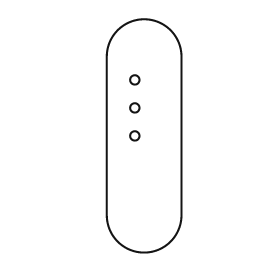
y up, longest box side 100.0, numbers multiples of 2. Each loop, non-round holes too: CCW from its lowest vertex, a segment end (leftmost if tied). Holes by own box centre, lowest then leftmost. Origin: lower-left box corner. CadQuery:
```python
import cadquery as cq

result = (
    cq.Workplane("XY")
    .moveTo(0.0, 16.0)
    .threePointArc((16.0, 0.0), (32.0, 16.0))
    .lineTo(32.0, 84.0)
    .threePointArc((16.0, 100.0), (0.0, 84.0))
    .close()
    .moveTo(12.0, 50.0)
    .circle(2.0)
    .moveTo(12.0, 62.0)
    .circle(2.0)
    .moveTo(12.0, 74.0)
    .circle(2.0)
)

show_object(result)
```